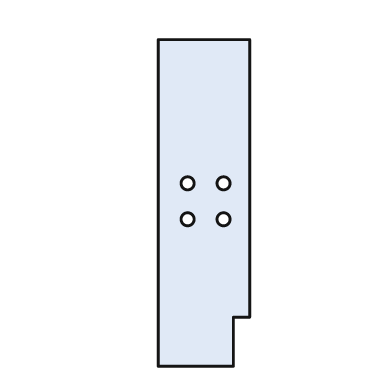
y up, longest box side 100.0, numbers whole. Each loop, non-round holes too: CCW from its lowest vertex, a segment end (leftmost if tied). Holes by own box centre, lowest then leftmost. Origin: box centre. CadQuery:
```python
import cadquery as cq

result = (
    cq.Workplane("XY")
    .moveTo(-14.0, -50.0)
    .lineTo(9.0, -50.0)
    .lineTo(9.0, -35.0)
    .lineTo(14.0, -35.0)
    .lineTo(14.0, 50.0)
    .lineTo(-14.0, 50.0)
    .close()
    .moveTo(-5.0, -5.0)
    .circle(2.0)
    .moveTo(6.0, -5.0)
    .circle(2.0)
    .moveTo(-5.0, 6.0)
    .circle(2.0)
    .moveTo(6.0, 6.0)
    .circle(2.0)
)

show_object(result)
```